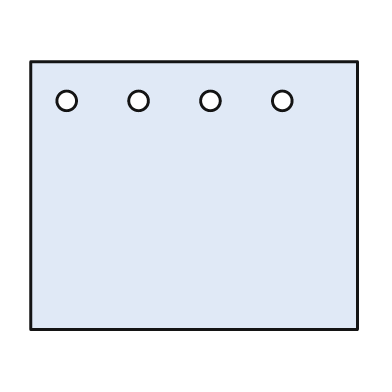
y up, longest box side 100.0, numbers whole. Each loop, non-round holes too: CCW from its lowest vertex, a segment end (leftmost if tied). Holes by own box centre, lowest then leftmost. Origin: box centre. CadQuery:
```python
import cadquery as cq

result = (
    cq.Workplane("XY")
    .moveTo(-50.0, -41.0)
    .lineTo(50.0, -41.0)
    .lineTo(50.0, 41.0)
    .lineTo(-50.0, 41.0)
    .close()
    .moveTo(-39.0, 29.0)
    .circle(3.0)
    .moveTo(-17.0, 29.0)
    .circle(3.0)
    .moveTo(5.0, 29.0)
    .circle(3.0)
    .moveTo(27.0, 29.0)
    .circle(3.0)
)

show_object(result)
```